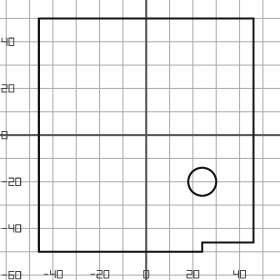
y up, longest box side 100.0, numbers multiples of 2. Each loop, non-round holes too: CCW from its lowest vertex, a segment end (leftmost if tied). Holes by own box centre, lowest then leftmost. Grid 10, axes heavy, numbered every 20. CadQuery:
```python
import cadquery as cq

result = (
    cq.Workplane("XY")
    .moveTo(-46.0, -50.0)
    .lineTo(24.0, -50.0)
    .lineTo(24.0, -46.0)
    .lineTo(46.0, -46.0)
    .lineTo(46.0, 50.0)
    .lineTo(-46.0, 50.0)
    .close()
    .moveTo(24.0, -20.0)
    .circle(6.0)
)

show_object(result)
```